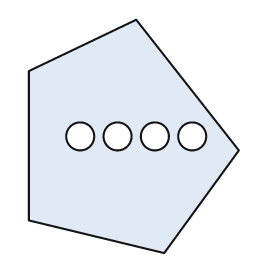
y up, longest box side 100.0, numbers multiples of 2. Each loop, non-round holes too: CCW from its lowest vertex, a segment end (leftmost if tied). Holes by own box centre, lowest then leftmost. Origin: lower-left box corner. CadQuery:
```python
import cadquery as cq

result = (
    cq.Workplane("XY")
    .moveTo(58.0, 0.0)
    .lineTo(90.0, 44.0)
    .lineTo(46.0, 100.0)
    .lineTo(0.0, 78.0)
    .lineTo(0.0, 14.0)
    .close()
    .moveTo(22.0, 50.0)
    .circle(6.0)
    .moveTo(38.0, 50.0)
    .circle(6.0)
    .moveTo(54.0, 50.0)
    .circle(6.0)
    .moveTo(70.0, 50.0)
    .circle(6.0)
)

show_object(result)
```